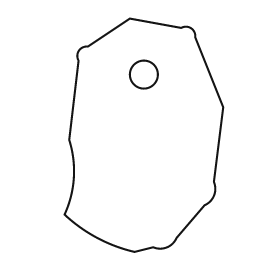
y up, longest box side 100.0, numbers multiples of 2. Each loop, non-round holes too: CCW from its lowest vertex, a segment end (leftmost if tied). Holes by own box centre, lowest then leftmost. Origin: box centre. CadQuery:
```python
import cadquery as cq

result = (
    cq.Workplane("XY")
    .moveTo(-4.0, -50.0)
    .lineTo(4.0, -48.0)
    .threePointArc((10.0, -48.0), (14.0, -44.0))
    .lineTo(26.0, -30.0)
    .threePointArc((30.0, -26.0), (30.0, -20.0))
    .lineTo(34.0, 12.0)
    .lineTo(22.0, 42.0)
    .threePointArc((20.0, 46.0), (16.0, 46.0))
    .lineTo(-6.0, 50.0)
    .lineTo(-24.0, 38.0)
    .threePointArc((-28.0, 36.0), (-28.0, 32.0))
    .lineTo(-32.0, -2.0)
    .threePointArc((-30.0, -18.0), (-34.0, -34.0))
    .threePointArc((-20.0, -44.0), (-4.0, -50.0))
    .close()
    .moveTo(0.0, 26.0)
    .circle(6.0)
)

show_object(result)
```